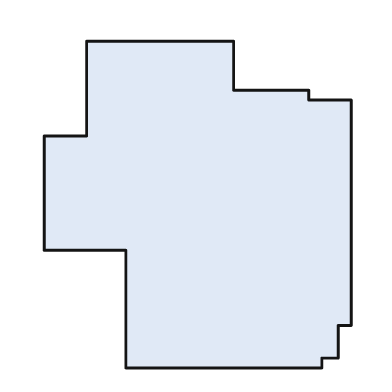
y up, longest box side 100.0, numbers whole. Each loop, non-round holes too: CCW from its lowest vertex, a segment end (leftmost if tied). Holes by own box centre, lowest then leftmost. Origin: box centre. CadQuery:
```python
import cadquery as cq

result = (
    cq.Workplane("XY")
    .moveTo(-22.0, -50.0)
    .lineTo(38.0, -50.0)
    .lineTo(38.0, -47.0)
    .lineTo(43.0, -47.0)
    .lineTo(43.0, -37.0)
    .lineTo(47.0, -37.0)
    .lineTo(47.0, 32.0)
    .lineTo(34.0, 32.0)
    .lineTo(34.0, 35.0)
    .lineTo(11.0, 35.0)
    .lineTo(11.0, 50.0)
    .lineTo(-34.0, 50.0)
    .lineTo(-34.0, 21.0)
    .lineTo(-47.0, 21.0)
    .lineTo(-47.0, -14.0)
    .lineTo(-22.0, -14.0)
    .close()
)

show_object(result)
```